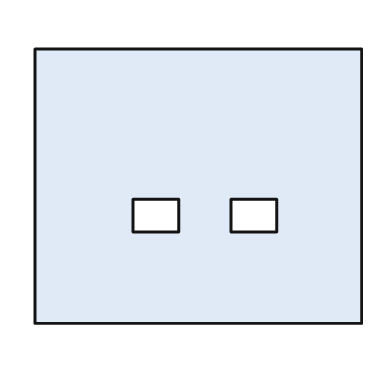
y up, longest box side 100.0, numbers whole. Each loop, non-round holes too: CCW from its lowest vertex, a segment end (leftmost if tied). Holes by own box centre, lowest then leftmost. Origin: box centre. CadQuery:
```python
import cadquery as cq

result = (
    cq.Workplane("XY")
    .moveTo(-50.0, -42.0)
    .lineTo(50.0, -42.0)
    .lineTo(50.0, 42.0)
    .lineTo(-50.0, 42.0)
    .close()
    .moveTo(-20.0, -14.0)
    .lineTo(-6.0, -14.0)
    .lineTo(-6.0, -4.0)
    .lineTo(-20.0, -4.0)
    .close()
    .moveTo(10.0, -14.0)
    .lineTo(24.0, -14.0)
    .lineTo(24.0, -4.0)
    .lineTo(10.0, -4.0)
    .close()
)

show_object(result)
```